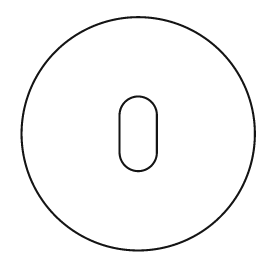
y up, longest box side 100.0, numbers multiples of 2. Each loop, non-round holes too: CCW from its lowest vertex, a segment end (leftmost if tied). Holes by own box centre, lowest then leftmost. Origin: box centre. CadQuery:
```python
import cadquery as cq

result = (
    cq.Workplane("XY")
    .moveTo(0.0, 0.0)
    .circle(50.0)
    .moveTo(-8.0, -8.0)
    .threePointArc((0.0, -16.0), (8.0, -8.0))
    .lineTo(8.0, 8.0)
    .threePointArc((0.0, 16.0), (-8.0, 8.0))
    .close()
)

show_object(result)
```